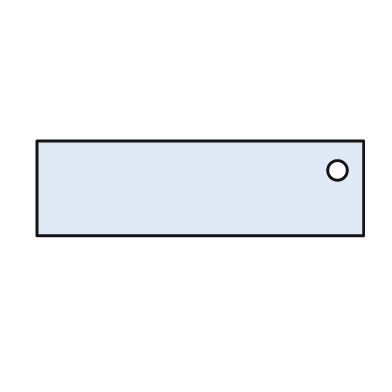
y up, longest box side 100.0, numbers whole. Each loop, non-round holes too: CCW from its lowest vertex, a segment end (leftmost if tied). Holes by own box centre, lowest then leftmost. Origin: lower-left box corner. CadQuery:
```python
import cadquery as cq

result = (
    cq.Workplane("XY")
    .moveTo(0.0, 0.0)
    .lineTo(100.0, 0.0)
    .lineTo(100.0, 29.0)
    .lineTo(0.0, 29.0)
    .close()
    .moveTo(92.0, 20.0)
    .circle(3.0)
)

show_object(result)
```